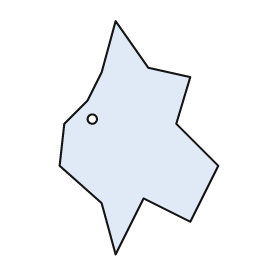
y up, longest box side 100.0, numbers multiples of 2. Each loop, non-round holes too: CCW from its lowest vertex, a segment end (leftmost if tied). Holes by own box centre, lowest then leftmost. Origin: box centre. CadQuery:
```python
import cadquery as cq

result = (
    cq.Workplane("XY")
    .moveTo(-10.0, -50.0)
    .lineTo(2.0, -26.0)
    .lineTo(22.0, -36.0)
    .lineTo(34.0, -12.0)
    .lineTo(16.0, 6.0)
    .lineTo(22.0, 26.0)
    .lineTo(4.0, 30.0)
    .lineTo(-10.0, 50.0)
    .lineTo(-16.0, 28.0)
    .lineTo(-22.0, 16.0)
    .lineTo(-32.0, 6.0)
    .lineTo(-34.0, -12.0)
    .lineTo(-16.0, -28.0)
    .close()
    .moveTo(-20.0, 8.0)
    .circle(2.0)
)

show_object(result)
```